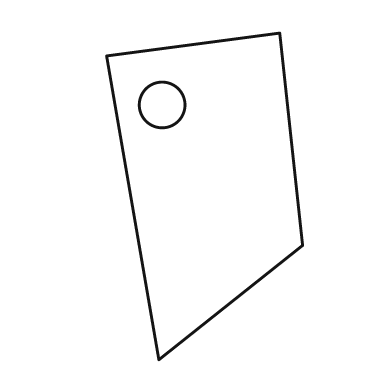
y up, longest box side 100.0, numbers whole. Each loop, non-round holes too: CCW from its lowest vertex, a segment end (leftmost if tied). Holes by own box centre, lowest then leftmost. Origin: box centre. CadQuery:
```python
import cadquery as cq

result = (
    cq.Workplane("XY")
    .moveTo(-14.0, -50.0)
    .lineTo(30.0, -15.0)
    .lineTo(23.0, 50.0)
    .lineTo(-30.0, 43.0)
    .close()
    .moveTo(-13.0, 28.0)
    .circle(7.0)
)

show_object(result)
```